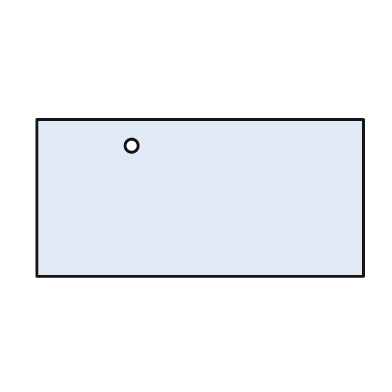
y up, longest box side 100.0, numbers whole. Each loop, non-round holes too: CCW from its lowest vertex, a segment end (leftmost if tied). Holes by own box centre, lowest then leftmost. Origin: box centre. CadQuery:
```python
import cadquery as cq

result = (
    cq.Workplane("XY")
    .moveTo(-50.0, -24.0)
    .lineTo(50.0, -24.0)
    .lineTo(50.0, 24.0)
    .lineTo(-50.0, 24.0)
    .close()
    .moveTo(-21.0, 16.0)
    .circle(2.0)
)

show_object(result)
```